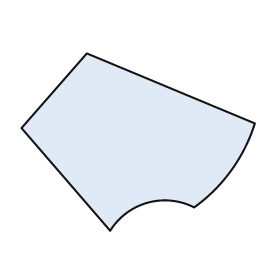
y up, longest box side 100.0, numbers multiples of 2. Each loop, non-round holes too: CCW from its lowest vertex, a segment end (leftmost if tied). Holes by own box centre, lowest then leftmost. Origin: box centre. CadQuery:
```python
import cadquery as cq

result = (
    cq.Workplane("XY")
    .moveTo(-12.0, -38.0)
    .threePointArc((4.0, -26.0), (24.0, -28.0))
    .threePointArc((40.0, -12.0), (50.0, 8.0))
    .lineTo(-22.0, 38.0)
    .lineTo(-50.0, 6.0)
    .close()
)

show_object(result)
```